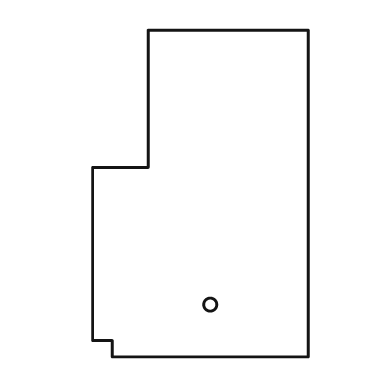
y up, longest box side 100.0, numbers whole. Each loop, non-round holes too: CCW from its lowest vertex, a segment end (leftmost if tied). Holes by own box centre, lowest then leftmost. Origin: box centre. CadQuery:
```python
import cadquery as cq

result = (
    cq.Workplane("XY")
    .moveTo(-27.0, -50.0)
    .lineTo(33.0, -50.0)
    .lineTo(33.0, 50.0)
    .lineTo(-16.0, 50.0)
    .lineTo(-16.0, 8.0)
    .lineTo(-33.0, 8.0)
    .lineTo(-33.0, -45.0)
    .lineTo(-27.0, -45.0)
    .close()
    .moveTo(3.0, -34.0)
    .circle(2.0)
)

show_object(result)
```